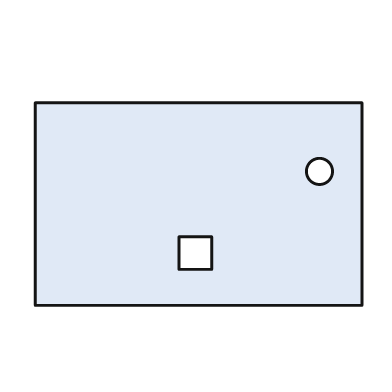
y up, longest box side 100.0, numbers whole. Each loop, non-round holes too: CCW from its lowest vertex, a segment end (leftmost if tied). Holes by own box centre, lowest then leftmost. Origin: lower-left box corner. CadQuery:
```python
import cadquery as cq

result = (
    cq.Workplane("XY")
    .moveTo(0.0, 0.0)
    .lineTo(100.0, 0.0)
    .lineTo(100.0, 62.0)
    .lineTo(0.0, 62.0)
    .close()
    .moveTo(44.0, 11.0)
    .lineTo(54.0, 11.0)
    .lineTo(54.0, 21.0)
    .lineTo(44.0, 21.0)
    .close()
    .moveTo(87.0, 41.0)
    .circle(4.0)
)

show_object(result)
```